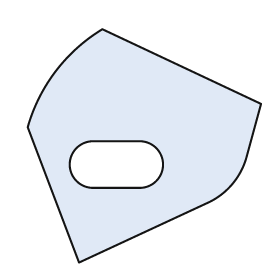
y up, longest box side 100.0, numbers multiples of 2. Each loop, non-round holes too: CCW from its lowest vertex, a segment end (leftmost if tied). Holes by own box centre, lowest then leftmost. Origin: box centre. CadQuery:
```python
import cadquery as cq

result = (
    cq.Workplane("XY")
    .moveTo(-28.0, -50.0)
    .lineTo(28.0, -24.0)
    .threePointArc((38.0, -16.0), (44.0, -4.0))
    .lineTo(50.0, 18.0)
    .lineTo(-18.0, 50.0)
    .threePointArc((-38.0, 32.0), (-50.0, 8.0))
    .close()
    .moveTo(-22.0, -18.0)
    .lineTo(-2.0, -18.0)
    .threePointArc((8.0, -8.0), (-2.0, 2.0))
    .lineTo(-22.0, 2.0)
    .threePointArc((-32.0, -8.0), (-22.0, -18.0))
    .close()
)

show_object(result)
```